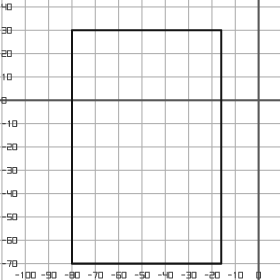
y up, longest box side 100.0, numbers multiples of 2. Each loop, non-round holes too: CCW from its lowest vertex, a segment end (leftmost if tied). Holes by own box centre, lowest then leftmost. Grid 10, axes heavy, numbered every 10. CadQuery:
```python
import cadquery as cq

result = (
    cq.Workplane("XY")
    .moveTo(-80.0, -70.0)
    .lineTo(-16.0, -70.0)
    .lineTo(-16.0, 30.0)
    .lineTo(-80.0, 30.0)
    .close()
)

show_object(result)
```